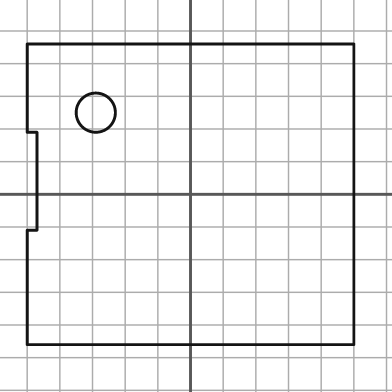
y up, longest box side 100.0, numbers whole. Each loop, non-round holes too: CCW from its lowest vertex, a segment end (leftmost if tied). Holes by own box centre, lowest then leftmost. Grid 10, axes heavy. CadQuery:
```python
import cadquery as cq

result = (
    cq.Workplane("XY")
    .moveTo(-50.0, -46.0)
    .lineTo(50.0, -46.0)
    .lineTo(50.0, 46.0)
    .lineTo(-50.0, 46.0)
    .lineTo(-50.0, 19.0)
    .lineTo(-47.0, 19.0)
    .lineTo(-47.0, -11.0)
    .lineTo(-50.0, -11.0)
    .close()
    .moveTo(-29.0, 25.0)
    .circle(6.0)
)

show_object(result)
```